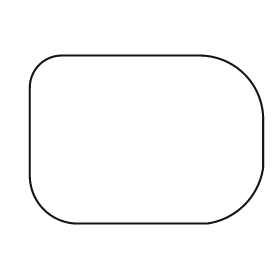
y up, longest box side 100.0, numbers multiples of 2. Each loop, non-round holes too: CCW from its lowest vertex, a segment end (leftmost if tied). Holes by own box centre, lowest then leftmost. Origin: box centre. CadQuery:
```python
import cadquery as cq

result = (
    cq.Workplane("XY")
    .moveTo(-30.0, -36.0)
    .lineTo(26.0, -36.0)
    .threePointArc((42.0, -28.0), (50.0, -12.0))
    .lineTo(50.0, 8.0)
    .threePointArc((42.0, 28.0), (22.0, 36.0))
    .lineTo(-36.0, 36.0)
    .threePointArc((-46.0, 32.0), (-50.0, 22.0))
    .lineTo(-50.0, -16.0)
    .threePointArc((-44.0, -30.0), (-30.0, -36.0))
    .close()
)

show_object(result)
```